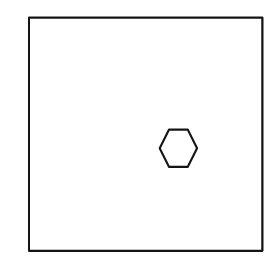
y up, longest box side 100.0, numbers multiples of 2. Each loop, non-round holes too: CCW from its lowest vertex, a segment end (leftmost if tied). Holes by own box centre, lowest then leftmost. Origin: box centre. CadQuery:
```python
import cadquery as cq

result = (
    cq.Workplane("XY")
    .moveTo(-50.0, -50.0)
    .lineTo(50.0, -50.0)
    .lineTo(50.0, 50.0)
    .lineTo(-50.0, 50.0)
    .close()
    .moveTo(10.0, -14.0)
    .lineTo(18.0, -14.0)
    .lineTo(22.0, -6.0)
    .lineTo(18.0, 2.0)
    .lineTo(10.0, 2.0)
    .lineTo(6.0, -6.0)
    .close()
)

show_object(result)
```